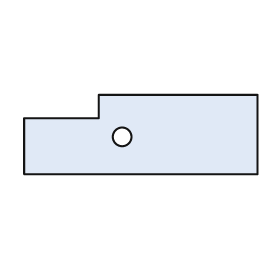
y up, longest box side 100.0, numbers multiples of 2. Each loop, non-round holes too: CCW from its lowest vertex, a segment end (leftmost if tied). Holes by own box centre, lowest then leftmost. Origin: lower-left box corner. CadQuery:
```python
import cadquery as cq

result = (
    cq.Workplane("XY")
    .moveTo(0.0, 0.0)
    .lineTo(100.0, 0.0)
    .lineTo(100.0, 34.0)
    .lineTo(32.0, 34.0)
    .lineTo(32.0, 24.0)
    .lineTo(0.0, 24.0)
    .close()
    .moveTo(42.0, 16.0)
    .circle(4.0)
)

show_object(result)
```